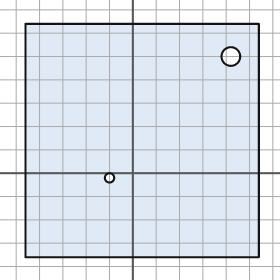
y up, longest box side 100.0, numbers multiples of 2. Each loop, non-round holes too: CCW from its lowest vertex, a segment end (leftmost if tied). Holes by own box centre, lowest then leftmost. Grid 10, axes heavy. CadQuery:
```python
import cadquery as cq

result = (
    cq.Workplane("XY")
    .moveTo(-46.0, -36.0)
    .lineTo(54.0, -36.0)
    .lineTo(54.0, 64.0)
    .lineTo(-46.0, 64.0)
    .close()
    .moveTo(-10.0, -2.0)
    .circle(2.0)
    .moveTo(42.0, 50.0)
    .circle(4.0)
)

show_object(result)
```